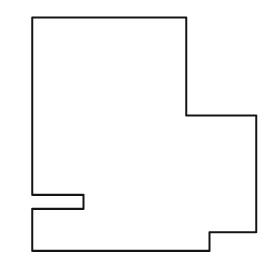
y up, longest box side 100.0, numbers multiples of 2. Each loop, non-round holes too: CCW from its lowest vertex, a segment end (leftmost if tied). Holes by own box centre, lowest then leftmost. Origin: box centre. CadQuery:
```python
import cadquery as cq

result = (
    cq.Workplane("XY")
    .moveTo(-48.0, -50.0)
    .lineTo(28.0, -50.0)
    .lineTo(28.0, -42.0)
    .lineTo(48.0, -42.0)
    .lineTo(48.0, 8.0)
    .lineTo(18.0, 8.0)
    .lineTo(18.0, 50.0)
    .lineTo(-48.0, 50.0)
    .lineTo(-48.0, -26.0)
    .lineTo(-26.0, -26.0)
    .lineTo(-26.0, -32.0)
    .lineTo(-48.0, -32.0)
    .close()
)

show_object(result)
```